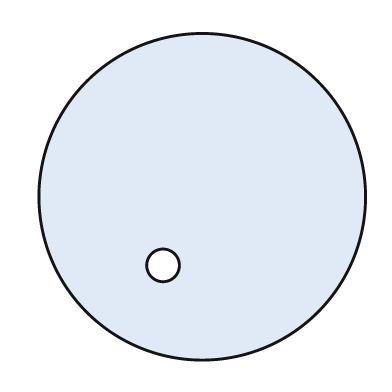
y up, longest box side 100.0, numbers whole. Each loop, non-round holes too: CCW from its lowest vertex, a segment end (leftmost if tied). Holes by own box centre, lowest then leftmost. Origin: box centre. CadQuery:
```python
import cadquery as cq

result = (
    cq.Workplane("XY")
    .moveTo(0.0, 0.0)
    .circle(50.0)
    .moveTo(-12.0, -21.0)
    .circle(5.0)
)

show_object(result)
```